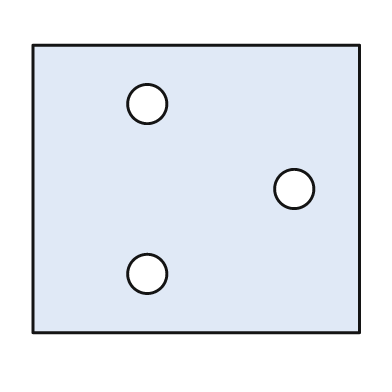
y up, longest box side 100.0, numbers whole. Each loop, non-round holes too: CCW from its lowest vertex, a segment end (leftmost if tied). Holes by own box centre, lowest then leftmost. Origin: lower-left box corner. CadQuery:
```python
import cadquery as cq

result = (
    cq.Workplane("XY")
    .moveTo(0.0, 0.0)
    .lineTo(100.0, 0.0)
    .lineTo(100.0, 88.0)
    .lineTo(0.0, 88.0)
    .close()
    .moveTo(35.0, 18.0)
    .circle(6.0)
    .moveTo(80.0, 44.0)
    .circle(6.0)
    .moveTo(35.0, 70.0)
    .circle(6.0)
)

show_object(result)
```